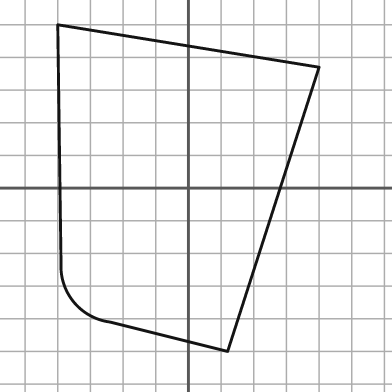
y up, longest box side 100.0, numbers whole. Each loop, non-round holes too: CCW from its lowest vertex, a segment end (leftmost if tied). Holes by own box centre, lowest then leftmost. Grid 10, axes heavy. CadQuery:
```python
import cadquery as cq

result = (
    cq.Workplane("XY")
    .moveTo(12.0, -50.0)
    .lineTo(40.0, 37.0)
    .lineTo(-40.0, 50.0)
    .lineTo(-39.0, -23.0)
    .threePointArc((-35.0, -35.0), (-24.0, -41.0))
    .close()
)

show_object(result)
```